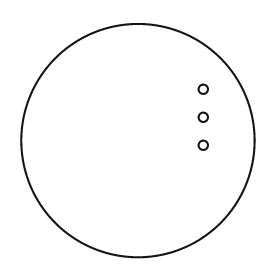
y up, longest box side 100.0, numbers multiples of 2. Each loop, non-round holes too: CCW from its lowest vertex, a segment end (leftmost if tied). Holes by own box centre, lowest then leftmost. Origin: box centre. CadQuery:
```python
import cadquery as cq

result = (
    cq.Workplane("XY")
    .moveTo(0.0, 0.0)
    .circle(50.0)
    .moveTo(28.0, -2.0)
    .circle(2.0)
    .moveTo(28.0, 10.0)
    .circle(2.0)
    .moveTo(28.0, 22.0)
    .circle(2.0)
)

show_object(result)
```